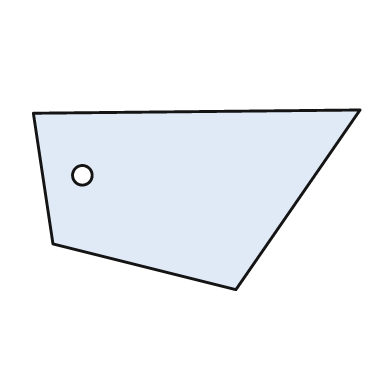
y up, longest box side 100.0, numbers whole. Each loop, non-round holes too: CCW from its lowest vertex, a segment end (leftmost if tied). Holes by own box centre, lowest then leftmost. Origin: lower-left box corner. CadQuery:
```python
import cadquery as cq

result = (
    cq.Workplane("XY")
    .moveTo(62.0, 0.0)
    .lineTo(100.0, 55.0)
    .lineTo(0.0, 54.0)
    .lineTo(6.0, 14.0)
    .close()
    .moveTo(15.0, 35.0)
    .circle(3.0)
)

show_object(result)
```